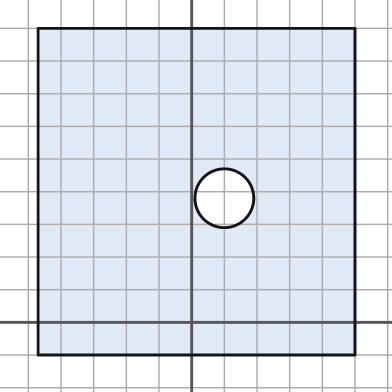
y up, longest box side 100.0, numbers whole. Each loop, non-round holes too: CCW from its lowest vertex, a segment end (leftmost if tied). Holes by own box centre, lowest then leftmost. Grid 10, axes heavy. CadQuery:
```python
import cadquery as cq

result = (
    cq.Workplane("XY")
    .moveTo(-47.0, -10.0)
    .lineTo(50.0, -10.0)
    .lineTo(50.0, 90.0)
    .lineTo(-47.0, 90.0)
    .close()
    .moveTo(10.0, 38.0)
    .circle(9.0)
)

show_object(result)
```